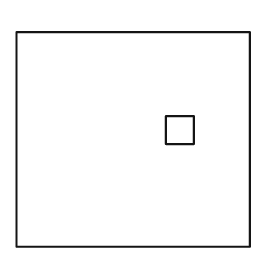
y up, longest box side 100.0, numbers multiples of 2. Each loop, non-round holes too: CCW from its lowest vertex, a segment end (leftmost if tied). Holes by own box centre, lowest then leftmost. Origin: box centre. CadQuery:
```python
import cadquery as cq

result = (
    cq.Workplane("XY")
    .moveTo(-50.0, -46.0)
    .lineTo(50.0, -46.0)
    .lineTo(50.0, 46.0)
    .lineTo(-50.0, 46.0)
    .close()
    .moveTo(14.0, -2.0)
    .lineTo(26.0, -2.0)
    .lineTo(26.0, 10.0)
    .lineTo(14.0, 10.0)
    .close()
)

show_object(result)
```